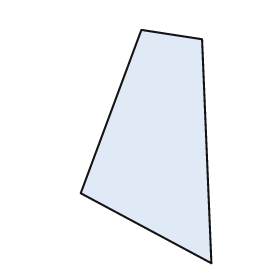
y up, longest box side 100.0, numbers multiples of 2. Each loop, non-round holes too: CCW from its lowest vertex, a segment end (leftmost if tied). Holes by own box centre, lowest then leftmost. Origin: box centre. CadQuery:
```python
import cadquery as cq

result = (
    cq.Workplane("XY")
    .moveTo(28.0, -50.0)
    .lineTo(24.0, 46.0)
    .lineTo(-2.0, 50.0)
    .lineTo(-28.0, -20.0)
    .close()
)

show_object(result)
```